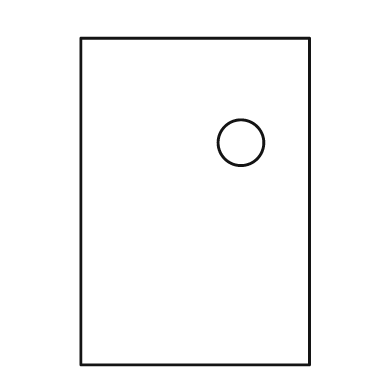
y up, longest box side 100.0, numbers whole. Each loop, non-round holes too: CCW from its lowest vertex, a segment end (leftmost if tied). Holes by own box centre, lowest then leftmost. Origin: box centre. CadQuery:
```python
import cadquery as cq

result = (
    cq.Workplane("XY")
    .moveTo(-35.0, -50.0)
    .lineTo(35.0, -50.0)
    .lineTo(35.0, 50.0)
    .lineTo(-35.0, 50.0)
    .close()
    .moveTo(14.0, 18.0)
    .circle(7.0)
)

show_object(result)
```